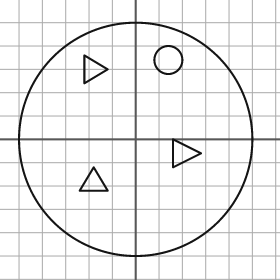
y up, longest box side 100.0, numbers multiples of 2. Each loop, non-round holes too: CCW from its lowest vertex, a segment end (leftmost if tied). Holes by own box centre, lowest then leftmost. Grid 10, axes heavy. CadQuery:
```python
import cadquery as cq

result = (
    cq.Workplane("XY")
    .moveTo(0.0, 0.0)
    .circle(50.0)
    .moveTo(-24.0, -22.0)
    .lineTo(-12.0, -22.0)
    .lineTo(-18.0, -12.0)
    .close()
    .moveTo(16.0, -12.0)
    .lineTo(28.0, -6.0)
    .lineTo(16.0, 0.0)
    .close()
    .moveTo(-22.0, 24.0)
    .lineTo(-12.0, 30.0)
    .lineTo(-22.0, 36.0)
    .close()
    .moveTo(14.0, 34.0)
    .circle(6.0)
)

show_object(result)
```